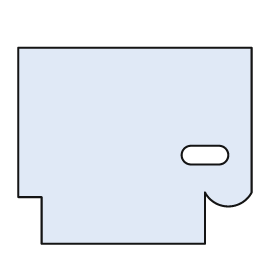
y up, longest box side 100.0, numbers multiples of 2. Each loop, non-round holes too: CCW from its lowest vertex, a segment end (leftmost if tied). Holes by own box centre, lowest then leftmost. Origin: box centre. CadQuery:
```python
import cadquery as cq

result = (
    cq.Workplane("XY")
    .moveTo(-40.0, -42.0)
    .lineTo(30.0, -42.0)
    .lineTo(30.0, -20.0)
    .threePointArc((40.0, -26.0), (50.0, -20.0))
    .lineTo(50.0, 42.0)
    .lineTo(-50.0, 42.0)
    .lineTo(-50.0, -22.0)
    .lineTo(-40.0, -22.0)
    .close()
    .moveTo(24.0, -8.0)
    .lineTo(36.0, -8.0)
    .threePointArc((40.0, -4.0), (36.0, 0.0))
    .lineTo(24.0, 0.0)
    .threePointArc((20.0, -4.0), (24.0, -8.0))
    .close()
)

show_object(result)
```